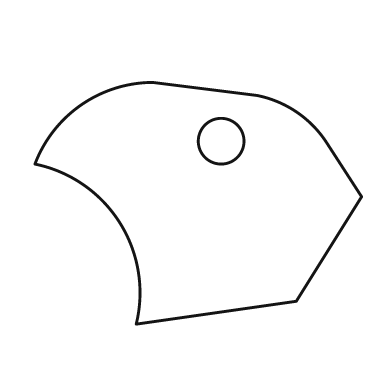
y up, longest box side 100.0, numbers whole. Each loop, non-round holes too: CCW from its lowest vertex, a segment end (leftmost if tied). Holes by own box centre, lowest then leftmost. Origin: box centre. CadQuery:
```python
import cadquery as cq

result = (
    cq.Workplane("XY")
    .moveTo(-19.0, -37.0)
    .lineTo(30.0, -30.0)
    .lineTo(50.0, 2.0)
    .lineTo(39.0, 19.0)
    .threePointArc((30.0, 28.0), (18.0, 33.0))
    .lineTo(-14.0, 37.0)
    .threePointArc((-36.0, 30.0), (-50.0, 12.0))
    .threePointArc((-24.0, -6.0), (-19.0, -37.0))
    .close()
    .moveTo(7.0, 19.0)
    .circle(7.0)
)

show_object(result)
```